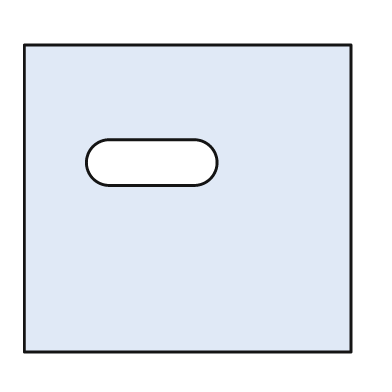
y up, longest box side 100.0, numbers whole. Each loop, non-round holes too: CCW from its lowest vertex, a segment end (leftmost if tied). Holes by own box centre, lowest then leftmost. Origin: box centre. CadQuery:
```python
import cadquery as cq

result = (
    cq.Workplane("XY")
    .moveTo(-50.0, -47.0)
    .lineTo(50.0, -47.0)
    .lineTo(50.0, 47.0)
    .lineTo(-50.0, 47.0)
    .close()
    .moveTo(-24.0, 4.0)
    .lineTo(2.0, 4.0)
    .threePointArc((9.0, 11.0), (2.0, 18.0))
    .lineTo(-24.0, 18.0)
    .threePointArc((-31.0, 11.0), (-24.0, 4.0))
    .close()
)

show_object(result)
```